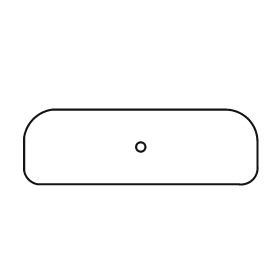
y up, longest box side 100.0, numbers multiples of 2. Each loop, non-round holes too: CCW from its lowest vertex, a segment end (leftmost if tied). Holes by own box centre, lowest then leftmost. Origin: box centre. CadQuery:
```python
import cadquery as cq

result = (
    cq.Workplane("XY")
    .moveTo(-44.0, -16.0)
    .lineTo(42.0, -16.0)
    .threePointArc((48.0, -14.0), (50.0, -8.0))
    .lineTo(50.0, 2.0)
    .threePointArc((46.0, 12.0), (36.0, 16.0))
    .lineTo(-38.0, 16.0)
    .threePointArc((-46.0, 12.0), (-50.0, 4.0))
    .lineTo(-50.0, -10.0)
    .threePointArc((-48.0, -14.0), (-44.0, -16.0))
    .close()
    .moveTo(0.0, 0.0)
    .circle(2.0)
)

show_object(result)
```